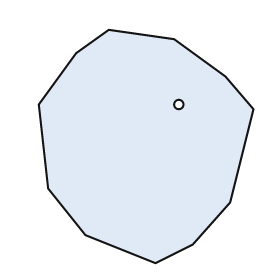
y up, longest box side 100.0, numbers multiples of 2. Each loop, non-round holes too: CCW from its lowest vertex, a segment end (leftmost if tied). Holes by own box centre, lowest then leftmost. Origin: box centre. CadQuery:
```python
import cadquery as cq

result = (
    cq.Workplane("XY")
    .moveTo(4.0, -50.0)
    .lineTo(20.0, -42.0)
    .lineTo(36.0, -24.0)
    .lineTo(46.0, 16.0)
    .lineTo(34.0, 30.0)
    .lineTo(12.0, 46.0)
    .lineTo(-16.0, 50.0)
    .lineTo(-30.0, 40.0)
    .lineTo(-46.0, 18.0)
    .lineTo(-42.0, -18.0)
    .lineTo(-26.0, -38.0)
    .close()
    .moveTo(14.0, 18.0)
    .circle(2.0)
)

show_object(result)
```